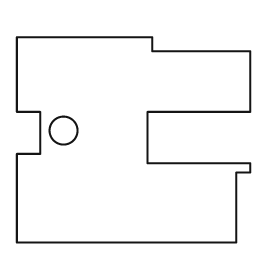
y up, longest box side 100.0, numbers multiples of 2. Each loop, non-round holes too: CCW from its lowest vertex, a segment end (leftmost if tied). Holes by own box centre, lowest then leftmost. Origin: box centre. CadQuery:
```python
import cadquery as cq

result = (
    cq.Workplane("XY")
    .moveTo(-50.0, -44.0)
    .lineTo(44.0, -44.0)
    .lineTo(44.0, -14.0)
    .lineTo(50.0, -14.0)
    .lineTo(50.0, -10.0)
    .lineTo(6.0, -10.0)
    .lineTo(6.0, 12.0)
    .lineTo(50.0, 12.0)
    .lineTo(50.0, 38.0)
    .lineTo(8.0, 38.0)
    .lineTo(8.0, 44.0)
    .lineTo(-50.0, 44.0)
    .lineTo(-50.0, 12.0)
    .lineTo(-40.0, 12.0)
    .lineTo(-40.0, -6.0)
    .lineTo(-50.0, -6.0)
    .close()
    .moveTo(-30.0, 4.0)
    .circle(6.0)
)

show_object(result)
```